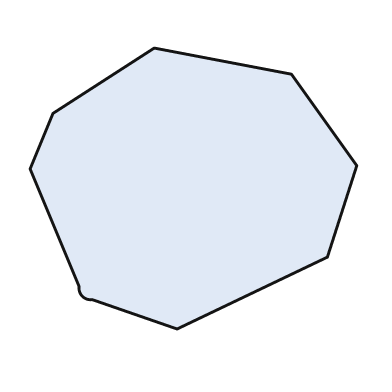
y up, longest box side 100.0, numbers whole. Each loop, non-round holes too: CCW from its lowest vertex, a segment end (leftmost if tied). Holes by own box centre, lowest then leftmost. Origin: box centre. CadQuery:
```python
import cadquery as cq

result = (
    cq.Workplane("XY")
    .moveTo(-5.0, -43.0)
    .lineTo(41.0, -21.0)
    .lineTo(50.0, 7.0)
    .lineTo(30.0, 35.0)
    .lineTo(-12.0, 43.0)
    .lineTo(-43.0, 23.0)
    .lineTo(-50.0, 6.0)
    .lineTo(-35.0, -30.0)
    .threePointArc((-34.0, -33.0), (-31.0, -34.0))
    .close()
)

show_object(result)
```